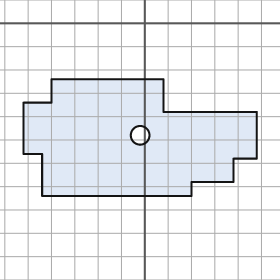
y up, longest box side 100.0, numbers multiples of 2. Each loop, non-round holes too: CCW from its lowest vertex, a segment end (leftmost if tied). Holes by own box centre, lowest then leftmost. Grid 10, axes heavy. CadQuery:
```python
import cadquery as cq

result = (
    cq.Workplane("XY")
    .moveTo(-44.0, -74.0)
    .lineTo(20.0, -74.0)
    .lineTo(20.0, -68.0)
    .lineTo(38.0, -68.0)
    .lineTo(38.0, -58.0)
    .lineTo(48.0, -58.0)
    .lineTo(48.0, -38.0)
    .lineTo(8.0, -38.0)
    .lineTo(8.0, -24.0)
    .lineTo(-40.0, -24.0)
    .lineTo(-40.0, -34.0)
    .lineTo(-52.0, -34.0)
    .lineTo(-52.0, -56.0)
    .lineTo(-44.0, -56.0)
    .close()
    .moveTo(-2.0, -48.0)
    .circle(4.0)
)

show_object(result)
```